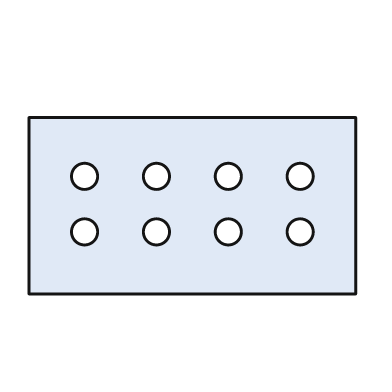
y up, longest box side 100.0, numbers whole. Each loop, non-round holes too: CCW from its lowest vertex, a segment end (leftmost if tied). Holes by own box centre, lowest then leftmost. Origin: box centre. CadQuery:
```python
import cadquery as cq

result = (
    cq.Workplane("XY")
    .moveTo(-50.0, -27.0)
    .lineTo(50.0, -27.0)
    .lineTo(50.0, 27.0)
    .lineTo(-50.0, 27.0)
    .close()
    .moveTo(-33.0, -8.0)
    .circle(4.0)
    .moveTo(-11.0, -8.0)
    .circle(4.0)
    .moveTo(11.0, -8.0)
    .circle(4.0)
    .moveTo(33.0, -8.0)
    .circle(4.0)
    .moveTo(-33.0, 9.0)
    .circle(4.0)
    .moveTo(-11.0, 9.0)
    .circle(4.0)
    .moveTo(11.0, 9.0)
    .circle(4.0)
    .moveTo(33.0, 9.0)
    .circle(4.0)
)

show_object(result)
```